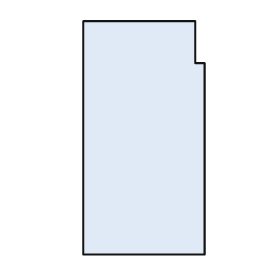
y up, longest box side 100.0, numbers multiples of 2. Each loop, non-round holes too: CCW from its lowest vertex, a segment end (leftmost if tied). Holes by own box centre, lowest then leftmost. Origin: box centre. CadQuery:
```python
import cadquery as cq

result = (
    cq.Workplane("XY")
    .moveTo(-26.0, -50.0)
    .lineTo(26.0, -50.0)
    .lineTo(26.0, 32.0)
    .lineTo(22.0, 32.0)
    .lineTo(22.0, 50.0)
    .lineTo(-26.0, 50.0)
    .close()
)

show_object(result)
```